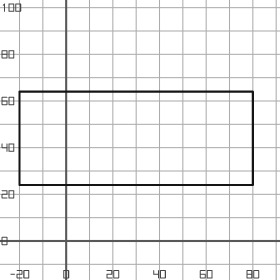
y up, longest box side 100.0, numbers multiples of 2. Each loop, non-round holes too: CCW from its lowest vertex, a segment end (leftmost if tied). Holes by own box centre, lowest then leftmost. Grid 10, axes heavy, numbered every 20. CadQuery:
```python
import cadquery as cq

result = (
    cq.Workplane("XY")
    .moveTo(-20.0, 24.0)
    .lineTo(80.0, 24.0)
    .lineTo(80.0, 64.0)
    .lineTo(-20.0, 64.0)
    .close()
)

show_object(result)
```